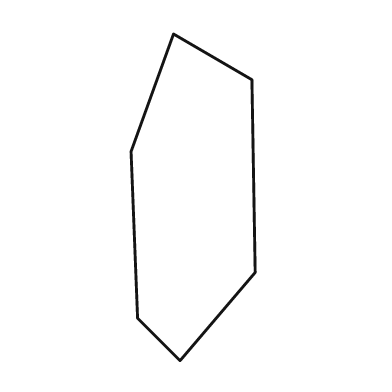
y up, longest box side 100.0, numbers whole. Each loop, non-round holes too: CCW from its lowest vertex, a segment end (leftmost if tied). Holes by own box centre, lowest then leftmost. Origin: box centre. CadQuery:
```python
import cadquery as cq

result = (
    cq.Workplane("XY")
    .moveTo(-4.0, -50.0)
    .lineTo(19.0, -23.0)
    .lineTo(18.0, 36.0)
    .lineTo(-6.0, 50.0)
    .lineTo(-19.0, 14.0)
    .lineTo(-17.0, -37.0)
    .close()
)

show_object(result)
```